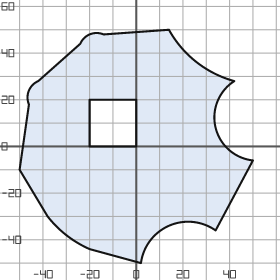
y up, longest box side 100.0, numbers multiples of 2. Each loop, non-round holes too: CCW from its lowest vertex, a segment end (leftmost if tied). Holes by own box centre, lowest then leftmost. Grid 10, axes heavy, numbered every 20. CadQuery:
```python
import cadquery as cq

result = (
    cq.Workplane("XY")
    .moveTo(2.0, -50.0)
    .threePointArc((14.0, -34.0), (34.0, -36.0))
    .lineTo(50.0, -6.0)
    .threePointArc((34.0, 8.0), (42.0, 28.0))
    .threePointArc((26.0, 36.0), (14.0, 50.0))
    .lineTo(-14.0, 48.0)
    .threePointArc((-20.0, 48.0), (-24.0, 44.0))
    .lineTo(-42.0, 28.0)
    .threePointArc((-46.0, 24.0), (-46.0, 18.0))
    .lineTo(-50.0, -10.0)
    .lineTo(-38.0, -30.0)
    .threePointArc((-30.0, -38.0), (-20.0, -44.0))
    .close()
    .moveTo(-20.0, 0.0)
    .lineTo(0.0, 0.0)
    .lineTo(0.0, 20.0)
    .lineTo(-20.0, 20.0)
    .close()
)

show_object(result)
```